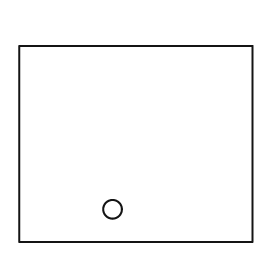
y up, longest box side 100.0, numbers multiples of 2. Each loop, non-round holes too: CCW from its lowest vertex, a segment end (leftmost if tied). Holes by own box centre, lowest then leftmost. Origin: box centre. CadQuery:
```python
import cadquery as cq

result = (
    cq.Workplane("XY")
    .moveTo(-50.0, -42.0)
    .lineTo(50.0, -42.0)
    .lineTo(50.0, 42.0)
    .lineTo(-50.0, 42.0)
    .close()
    .moveTo(-10.0, -28.0)
    .circle(4.0)
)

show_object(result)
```